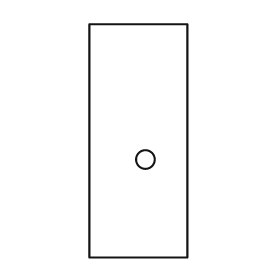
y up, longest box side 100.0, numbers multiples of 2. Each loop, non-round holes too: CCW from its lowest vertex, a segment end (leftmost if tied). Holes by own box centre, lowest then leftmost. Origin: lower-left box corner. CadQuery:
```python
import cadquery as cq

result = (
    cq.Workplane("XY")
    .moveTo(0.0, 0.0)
    .lineTo(42.0, 0.0)
    .lineTo(42.0, 100.0)
    .lineTo(0.0, 100.0)
    .close()
    .moveTo(24.0, 42.0)
    .circle(4.0)
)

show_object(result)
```